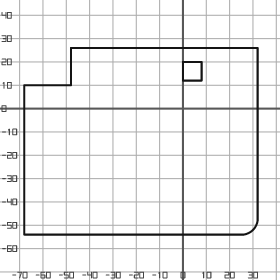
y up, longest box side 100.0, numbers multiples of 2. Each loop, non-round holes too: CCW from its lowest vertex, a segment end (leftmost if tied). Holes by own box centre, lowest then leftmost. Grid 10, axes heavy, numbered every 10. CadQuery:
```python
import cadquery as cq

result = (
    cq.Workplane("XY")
    .moveTo(-68.0, -54.0)
    .lineTo(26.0, -54.0)
    .threePointArc((30.0, -52.0), (32.0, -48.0))
    .lineTo(32.0, 26.0)
    .lineTo(-48.0, 26.0)
    .lineTo(-48.0, 10.0)
    .lineTo(-68.0, 10.0)
    .close()
    .moveTo(0.0, 12.0)
    .lineTo(8.0, 12.0)
    .lineTo(8.0, 20.0)
    .lineTo(0.0, 20.0)
    .close()
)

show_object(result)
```